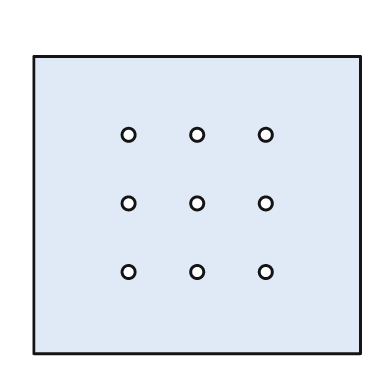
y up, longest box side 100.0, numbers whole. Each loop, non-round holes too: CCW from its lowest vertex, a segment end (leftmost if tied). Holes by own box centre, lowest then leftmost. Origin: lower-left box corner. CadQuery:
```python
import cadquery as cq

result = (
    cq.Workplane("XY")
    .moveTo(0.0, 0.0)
    .lineTo(100.0, 0.0)
    .lineTo(100.0, 91.0)
    .lineTo(0.0, 91.0)
    .close()
    .moveTo(29.0, 25.0)
    .circle(2.0)
    .moveTo(50.0, 25.0)
    .circle(2.0)
    .moveTo(71.0, 25.0)
    .circle(2.0)
    .moveTo(29.0, 46.0)
    .circle(2.0)
    .moveTo(50.0, 46.0)
    .circle(2.0)
    .moveTo(71.0, 46.0)
    .circle(2.0)
    .moveTo(29.0, 67.0)
    .circle(2.0)
    .moveTo(50.0, 67.0)
    .circle(2.0)
    .moveTo(71.0, 67.0)
    .circle(2.0)
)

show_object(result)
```